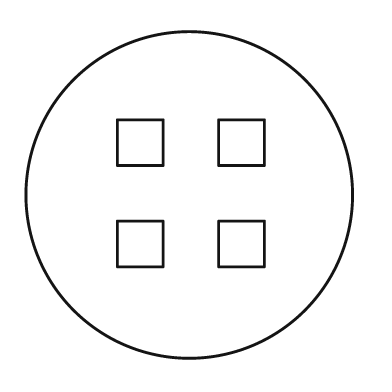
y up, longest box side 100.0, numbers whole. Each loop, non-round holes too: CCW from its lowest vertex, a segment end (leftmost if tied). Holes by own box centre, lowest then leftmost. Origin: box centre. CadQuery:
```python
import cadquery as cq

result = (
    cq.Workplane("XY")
    .moveTo(0.0, 0.0)
    .circle(50.0)
    .moveTo(-22.0, -22.0)
    .lineTo(-8.0, -22.0)
    .lineTo(-8.0, -8.0)
    .lineTo(-22.0, -8.0)
    .close()
    .moveTo(9.0, -22.0)
    .lineTo(23.0, -22.0)
    .lineTo(23.0, -8.0)
    .lineTo(9.0, -8.0)
    .close()
    .moveTo(-22.0, 9.0)
    .lineTo(-8.0, 9.0)
    .lineTo(-8.0, 23.0)
    .lineTo(-22.0, 23.0)
    .close()
    .moveTo(9.0, 9.0)
    .lineTo(23.0, 9.0)
    .lineTo(23.0, 23.0)
    .lineTo(9.0, 23.0)
    .close()
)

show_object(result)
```